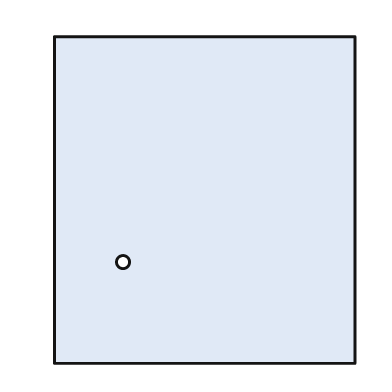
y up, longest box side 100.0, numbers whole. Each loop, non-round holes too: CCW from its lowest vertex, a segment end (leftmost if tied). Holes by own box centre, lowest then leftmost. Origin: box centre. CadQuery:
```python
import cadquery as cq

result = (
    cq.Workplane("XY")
    .moveTo(-46.0, -50.0)
    .lineTo(46.0, -50.0)
    .lineTo(46.0, 50.0)
    .lineTo(-46.0, 50.0)
    .close()
    .moveTo(-25.0, -19.0)
    .circle(2.0)
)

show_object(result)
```